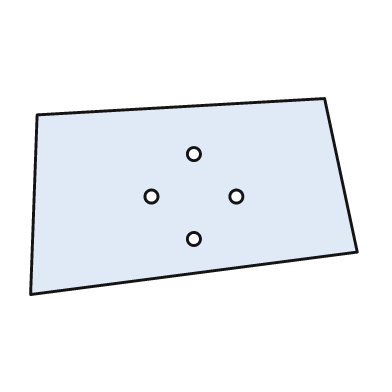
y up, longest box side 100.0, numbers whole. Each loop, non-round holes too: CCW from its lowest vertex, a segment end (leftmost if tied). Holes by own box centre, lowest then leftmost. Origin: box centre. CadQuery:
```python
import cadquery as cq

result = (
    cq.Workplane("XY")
    .moveTo(-50.0, -30.0)
    .lineTo(50.0, -17.0)
    .lineTo(40.0, 30.0)
    .lineTo(-48.0, 25.0)
    .close()
    .moveTo(0.0, -13.0)
    .circle(2.0)
    .moveTo(-13.0, 0.0)
    .circle(2.0)
    .moveTo(13.0, 0.0)
    .circle(2.0)
    .moveTo(0.0, 13.0)
    .circle(2.0)
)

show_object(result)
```